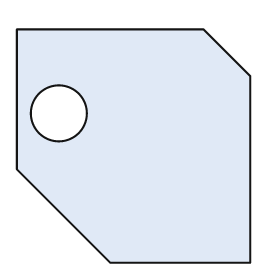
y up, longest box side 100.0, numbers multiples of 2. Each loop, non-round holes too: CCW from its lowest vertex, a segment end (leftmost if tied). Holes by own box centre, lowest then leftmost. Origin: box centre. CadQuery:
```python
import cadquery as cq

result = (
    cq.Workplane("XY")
    .moveTo(-10.0, -50.0)
    .lineTo(50.0, -50.0)
    .lineTo(50.0, 30.0)
    .lineTo(30.0, 50.0)
    .lineTo(-50.0, 50.0)
    .lineTo(-50.0, -10.0)
    .close()
    .moveTo(-32.0, 14.0)
    .circle(12.0)
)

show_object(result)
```